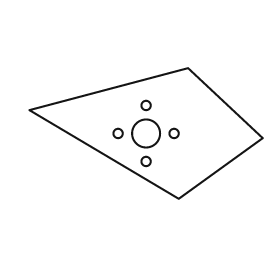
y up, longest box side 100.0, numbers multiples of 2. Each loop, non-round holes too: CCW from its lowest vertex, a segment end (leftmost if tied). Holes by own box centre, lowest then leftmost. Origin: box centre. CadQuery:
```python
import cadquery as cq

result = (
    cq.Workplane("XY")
    .moveTo(14.0, -28.0)
    .lineTo(50.0, -2.0)
    .lineTo(18.0, 28.0)
    .lineTo(-50.0, 10.0)
    .close()
    .moveTo(0.0, -12.0)
    .circle(2.0)
    .moveTo(-12.0, 0.0)
    .circle(2.0)
    .moveTo(0.0, 0.0)
    .circle(6.0)
    .moveTo(12.0, 0.0)
    .circle(2.0)
    .moveTo(0.0, 12.0)
    .circle(2.0)
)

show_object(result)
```